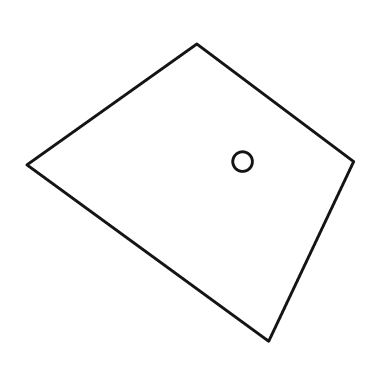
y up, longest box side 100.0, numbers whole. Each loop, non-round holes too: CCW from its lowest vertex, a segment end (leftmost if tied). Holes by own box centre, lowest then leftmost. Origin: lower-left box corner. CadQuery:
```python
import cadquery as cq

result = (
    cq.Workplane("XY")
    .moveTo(74.0, 0.0)
    .lineTo(100.0, 55.0)
    .lineTo(52.0, 91.0)
    .lineTo(0.0, 54.0)
    .close()
    .moveTo(66.0, 55.0)
    .circle(3.0)
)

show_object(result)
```